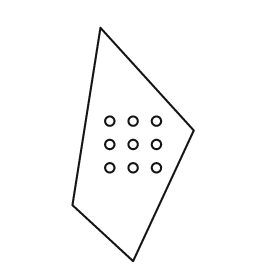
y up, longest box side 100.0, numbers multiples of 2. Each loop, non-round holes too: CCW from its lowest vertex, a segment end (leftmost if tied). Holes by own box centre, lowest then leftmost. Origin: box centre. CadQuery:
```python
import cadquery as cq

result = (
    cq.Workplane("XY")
    .moveTo(0.0, -50.0)
    .lineTo(26.0, 6.0)
    .lineTo(-14.0, 50.0)
    .lineTo(-26.0, -26.0)
    .close()
    .moveTo(-10.0, -10.0)
    .circle(2.0)
    .moveTo(0.0, -10.0)
    .circle(2.0)
    .moveTo(10.0, -10.0)
    .circle(2.0)
    .moveTo(-10.0, 0.0)
    .circle(2.0)
    .moveTo(0.0, 0.0)
    .circle(2.0)
    .moveTo(10.0, 0.0)
    .circle(2.0)
    .moveTo(-10.0, 10.0)
    .circle(2.0)
    .moveTo(0.0, 10.0)
    .circle(2.0)
    .moveTo(10.0, 10.0)
    .circle(2.0)
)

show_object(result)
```